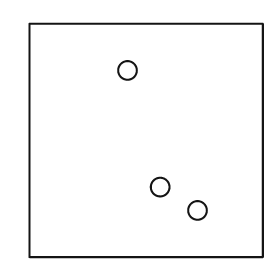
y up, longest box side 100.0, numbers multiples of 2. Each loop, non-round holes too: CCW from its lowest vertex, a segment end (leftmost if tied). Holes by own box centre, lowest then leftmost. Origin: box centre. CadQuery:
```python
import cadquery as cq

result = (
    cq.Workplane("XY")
    .moveTo(-50.0, -50.0)
    .lineTo(50.0, -50.0)
    .lineTo(50.0, 50.0)
    .lineTo(-50.0, 50.0)
    .close()
    .moveTo(22.0, -30.0)
    .circle(4.0)
    .moveTo(6.0, -20.0)
    .circle(4.0)
    .moveTo(-8.0, 30.0)
    .circle(4.0)
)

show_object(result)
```